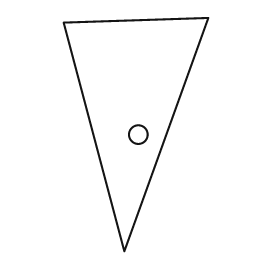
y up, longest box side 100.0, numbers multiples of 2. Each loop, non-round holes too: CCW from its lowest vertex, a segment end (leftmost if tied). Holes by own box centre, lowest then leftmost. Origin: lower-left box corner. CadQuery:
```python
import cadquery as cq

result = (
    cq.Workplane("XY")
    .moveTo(26.0, 0.0)
    .lineTo(62.0, 100.0)
    .lineTo(0.0, 98.0)
    .close()
    .moveTo(32.0, 50.0)
    .circle(4.0)
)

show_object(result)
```